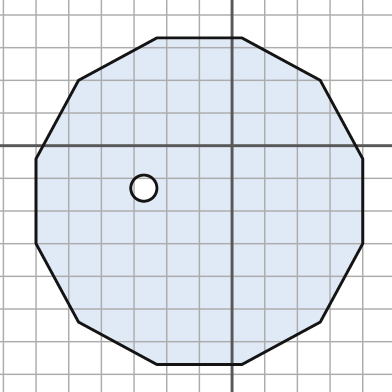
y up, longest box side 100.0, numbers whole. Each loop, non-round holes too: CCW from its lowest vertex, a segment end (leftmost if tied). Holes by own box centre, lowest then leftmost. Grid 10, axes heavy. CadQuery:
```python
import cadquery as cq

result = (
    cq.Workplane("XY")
    .moveTo(-23.0, -67.0)
    .lineTo(3.0, -67.0)
    .lineTo(27.0, -54.0)
    .lineTo(40.0, -30.0)
    .lineTo(40.0, -4.0)
    .lineTo(27.0, 20.0)
    .lineTo(3.0, 33.0)
    .lineTo(-23.0, 33.0)
    .lineTo(-47.0, 20.0)
    .lineTo(-60.0, -4.0)
    .lineTo(-60.0, -30.0)
    .lineTo(-47.0, -54.0)
    .close()
    .moveTo(-27.0, -13.0)
    .circle(4.0)
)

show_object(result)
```